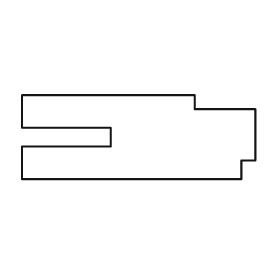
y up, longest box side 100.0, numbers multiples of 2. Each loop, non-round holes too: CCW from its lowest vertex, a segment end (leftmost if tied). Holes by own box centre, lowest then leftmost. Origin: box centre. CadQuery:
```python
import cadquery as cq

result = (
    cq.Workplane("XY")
    .moveTo(-50.0, -18.0)
    .lineTo(44.0, -18.0)
    .lineTo(44.0, -10.0)
    .lineTo(50.0, -10.0)
    .lineTo(50.0, 12.0)
    .lineTo(24.0, 12.0)
    .lineTo(24.0, 18.0)
    .lineTo(-50.0, 18.0)
    .lineTo(-50.0, 4.0)
    .lineTo(-12.0, 4.0)
    .lineTo(-12.0, -4.0)
    .lineTo(-50.0, -4.0)
    .close()
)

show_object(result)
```